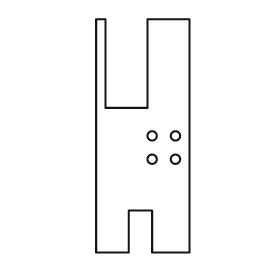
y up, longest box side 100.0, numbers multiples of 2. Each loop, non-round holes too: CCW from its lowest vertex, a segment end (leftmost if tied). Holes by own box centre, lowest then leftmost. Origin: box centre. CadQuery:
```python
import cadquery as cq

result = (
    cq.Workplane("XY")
    .moveTo(-20.0, -50.0)
    .lineTo(-6.0, -50.0)
    .lineTo(-6.0, -32.0)
    .lineTo(4.0, -32.0)
    .lineTo(4.0, -50.0)
    .lineTo(20.0, -50.0)
    .lineTo(20.0, 50.0)
    .lineTo(2.0, 50.0)
    .lineTo(2.0, 12.0)
    .lineTo(-16.0, 12.0)
    .lineTo(-16.0, 50.0)
    .lineTo(-20.0, 50.0)
    .close()
    .moveTo(4.0, -10.0)
    .circle(2.0)
    .moveTo(14.0, -10.0)
    .circle(2.0)
    .moveTo(4.0, 0.0)
    .circle(2.0)
    .moveTo(14.0, 0.0)
    .circle(2.0)
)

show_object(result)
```